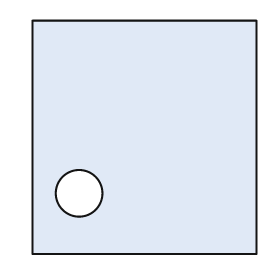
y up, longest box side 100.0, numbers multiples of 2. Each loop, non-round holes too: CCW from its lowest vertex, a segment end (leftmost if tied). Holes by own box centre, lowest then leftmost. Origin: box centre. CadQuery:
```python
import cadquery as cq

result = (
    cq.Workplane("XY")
    .moveTo(-48.0, -50.0)
    .lineTo(48.0, -50.0)
    .lineTo(48.0, 50.0)
    .lineTo(-48.0, 50.0)
    .close()
    .moveTo(-28.0, -24.0)
    .circle(10.0)
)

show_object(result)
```